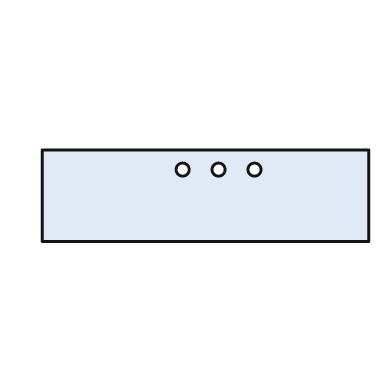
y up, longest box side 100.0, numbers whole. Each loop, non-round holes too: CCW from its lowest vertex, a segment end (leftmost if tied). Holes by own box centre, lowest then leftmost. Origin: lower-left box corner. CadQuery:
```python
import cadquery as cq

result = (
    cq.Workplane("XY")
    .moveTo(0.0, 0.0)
    .lineTo(100.0, 0.0)
    .lineTo(100.0, 28.0)
    .lineTo(0.0, 28.0)
    .close()
    .moveTo(43.0, 22.0)
    .circle(2.0)
    .moveTo(54.0, 22.0)
    .circle(2.0)
    .moveTo(65.0, 22.0)
    .circle(2.0)
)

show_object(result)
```